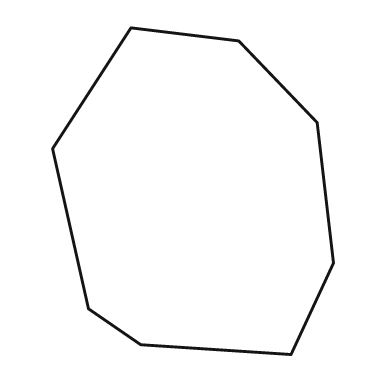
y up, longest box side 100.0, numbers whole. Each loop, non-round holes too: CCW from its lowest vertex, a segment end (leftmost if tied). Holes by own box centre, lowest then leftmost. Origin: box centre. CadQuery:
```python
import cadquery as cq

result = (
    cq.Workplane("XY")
    .moveTo(30.0, -50.0)
    .lineTo(43.0, -22.0)
    .lineTo(38.0, 21.0)
    .lineTo(14.0, 46.0)
    .lineTo(-19.0, 50.0)
    .lineTo(-43.0, 13.0)
    .lineTo(-32.0, -36.0)
    .lineTo(-16.0, -47.0)
    .close()
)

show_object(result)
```